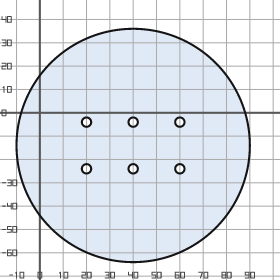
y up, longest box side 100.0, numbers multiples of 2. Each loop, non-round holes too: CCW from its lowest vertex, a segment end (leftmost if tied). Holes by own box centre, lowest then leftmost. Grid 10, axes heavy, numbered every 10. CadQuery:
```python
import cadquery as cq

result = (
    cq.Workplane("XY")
    .moveTo(40.0, -14.0)
    .circle(50.0)
    .moveTo(20.0, -24.0)
    .circle(2.0)
    .moveTo(40.0, -24.0)
    .circle(2.0)
    .moveTo(60.0, -24.0)
    .circle(2.0)
    .moveTo(20.0, -4.0)
    .circle(2.0)
    .moveTo(40.0, -4.0)
    .circle(2.0)
    .moveTo(60.0, -4.0)
    .circle(2.0)
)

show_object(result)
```